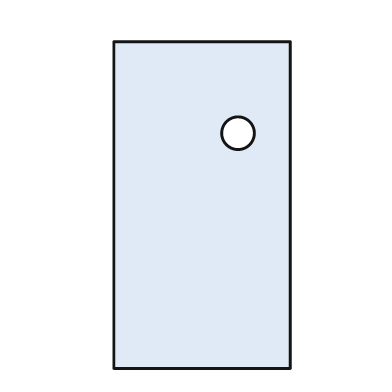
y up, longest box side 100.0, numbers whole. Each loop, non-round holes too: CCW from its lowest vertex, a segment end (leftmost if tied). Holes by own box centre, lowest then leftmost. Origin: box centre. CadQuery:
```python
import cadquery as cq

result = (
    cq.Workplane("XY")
    .moveTo(-27.0, -50.0)
    .lineTo(27.0, -50.0)
    .lineTo(27.0, 50.0)
    .lineTo(-27.0, 50.0)
    .close()
    .moveTo(11.0, 22.0)
    .circle(5.0)
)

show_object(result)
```